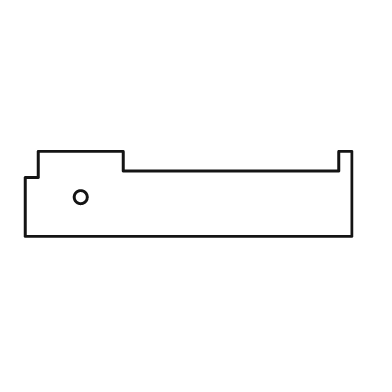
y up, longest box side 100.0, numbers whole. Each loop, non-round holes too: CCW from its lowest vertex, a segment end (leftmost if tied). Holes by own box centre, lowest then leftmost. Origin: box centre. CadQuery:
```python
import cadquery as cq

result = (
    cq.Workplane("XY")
    .moveTo(-50.0, -13.0)
    .lineTo(50.0, -13.0)
    .lineTo(50.0, 13.0)
    .lineTo(46.0, 13.0)
    .lineTo(46.0, 7.0)
    .lineTo(-20.0, 7.0)
    .lineTo(-20.0, 13.0)
    .lineTo(-46.0, 13.0)
    .lineTo(-46.0, 5.0)
    .lineTo(-50.0, 5.0)
    .close()
    .moveTo(-33.0, -1.0)
    .circle(2.0)
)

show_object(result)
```